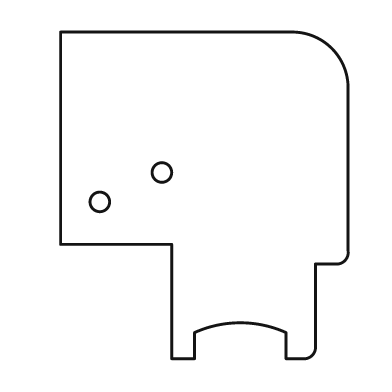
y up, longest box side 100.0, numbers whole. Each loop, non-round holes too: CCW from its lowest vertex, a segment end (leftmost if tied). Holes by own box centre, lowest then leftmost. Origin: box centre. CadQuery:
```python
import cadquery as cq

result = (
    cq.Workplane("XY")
    .moveTo(-10.0, -50.0)
    .lineTo(-3.0, -50.0)
    .lineTo(-3.0, -42.0)
    .threePointArc((11.0, -39.0), (25.0, -42.0))
    .lineTo(25.0, -50.0)
    .lineTo(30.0, -50.0)
    .threePointArc((33.0, -49.0), (34.0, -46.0))
    .lineTo(34.0, -21.0)
    .lineTo(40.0, -21.0)
    .threePointArc((43.0, -20.0), (44.0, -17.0))
    .lineTo(44.0, 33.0)
    .threePointArc((39.0, 45.0), (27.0, 50.0))
    .lineTo(-44.0, 50.0)
    .lineTo(-44.0, -15.0)
    .lineTo(-10.0, -15.0)
    .close()
    .moveTo(-32.0, -2.0)
    .circle(3.0)
    .moveTo(-13.0, 7.0)
    .circle(3.0)
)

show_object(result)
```